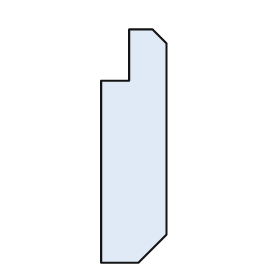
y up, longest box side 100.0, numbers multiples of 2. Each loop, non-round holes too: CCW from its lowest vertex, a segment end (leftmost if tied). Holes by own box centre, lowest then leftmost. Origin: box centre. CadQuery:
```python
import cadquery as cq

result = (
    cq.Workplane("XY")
    .moveTo(-14.0, -50.0)
    .lineTo(2.0, -50.0)
    .lineTo(14.0, -38.0)
    .lineTo(14.0, 44.0)
    .lineTo(8.0, 50.0)
    .lineTo(-2.0, 50.0)
    .lineTo(-2.0, 28.0)
    .lineTo(-14.0, 28.0)
    .close()
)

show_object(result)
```